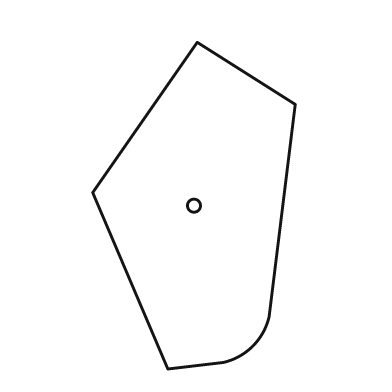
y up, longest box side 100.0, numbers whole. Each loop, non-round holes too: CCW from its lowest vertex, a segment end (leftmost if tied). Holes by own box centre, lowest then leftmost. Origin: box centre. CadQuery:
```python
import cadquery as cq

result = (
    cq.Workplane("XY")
    .moveTo(-8.0, -50.0)
    .lineTo(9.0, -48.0)
    .threePointArc((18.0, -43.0), (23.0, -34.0))
    .lineTo(31.0, 31.0)
    .lineTo(1.0, 50.0)
    .lineTo(-31.0, 4.0)
    .close()
    .moveTo(0.0, 0.0)
    .circle(2.0)
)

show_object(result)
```